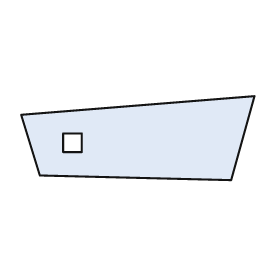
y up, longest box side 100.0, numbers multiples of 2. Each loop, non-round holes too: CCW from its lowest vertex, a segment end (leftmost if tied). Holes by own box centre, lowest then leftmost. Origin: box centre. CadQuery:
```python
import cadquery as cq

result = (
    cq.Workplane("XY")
    .moveTo(40.0, -18.0)
    .lineTo(50.0, 18.0)
    .lineTo(-50.0, 10.0)
    .lineTo(-42.0, -16.0)
    .close()
    .moveTo(-32.0, -6.0)
    .lineTo(-24.0, -6.0)
    .lineTo(-24.0, 2.0)
    .lineTo(-32.0, 2.0)
    .close()
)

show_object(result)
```